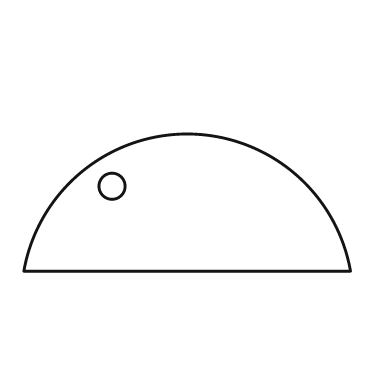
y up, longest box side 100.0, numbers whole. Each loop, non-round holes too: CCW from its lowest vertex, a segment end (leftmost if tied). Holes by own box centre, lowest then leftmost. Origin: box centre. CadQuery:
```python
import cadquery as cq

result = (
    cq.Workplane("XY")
    .moveTo(-50.0, -21.0)
    .lineTo(50.0, -21.0)
    .threePointArc((0.0, 21.0), (-50.0, -21.0))
    .close()
    .moveTo(-23.0, 5.0)
    .circle(4.0)
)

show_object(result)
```